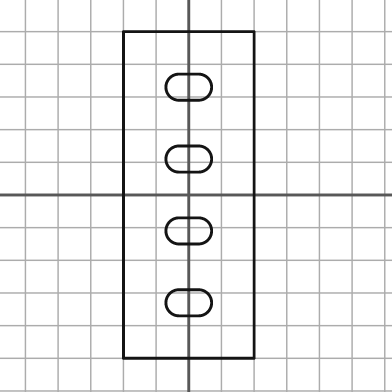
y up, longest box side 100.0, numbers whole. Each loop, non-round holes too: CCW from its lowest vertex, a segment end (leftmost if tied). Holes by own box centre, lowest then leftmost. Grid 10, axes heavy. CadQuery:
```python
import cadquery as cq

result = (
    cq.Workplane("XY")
    .moveTo(-20.0, -50.0)
    .lineTo(20.0, -50.0)
    .lineTo(20.0, 50.0)
    .lineTo(-20.0, 50.0)
    .close()
    .moveTo(-3.0, -37.0)
    .lineTo(3.0, -37.0)
    .threePointArc((7.0, -33.0), (3.0, -29.0))
    .lineTo(-3.0, -29.0)
    .threePointArc((-7.0, -33.0), (-3.0, -37.0))
    .close()
    .moveTo(-3.0, -15.0)
    .lineTo(3.0, -15.0)
    .threePointArc((7.0, -11.0), (3.0, -7.0))
    .lineTo(-3.0, -7.0)
    .threePointArc((-7.0, -11.0), (-3.0, -15.0))
    .close()
    .moveTo(-3.0, 7.0)
    .lineTo(3.0, 7.0)
    .threePointArc((7.0, 11.0), (3.0, 15.0))
    .lineTo(-3.0, 15.0)
    .threePointArc((-7.0, 11.0), (-3.0, 7.0))
    .close()
    .moveTo(-3.0, 29.0)
    .lineTo(3.0, 29.0)
    .threePointArc((7.0, 33.0), (3.0, 37.0))
    .lineTo(-3.0, 37.0)
    .threePointArc((-7.0, 33.0), (-3.0, 29.0))
    .close()
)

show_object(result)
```